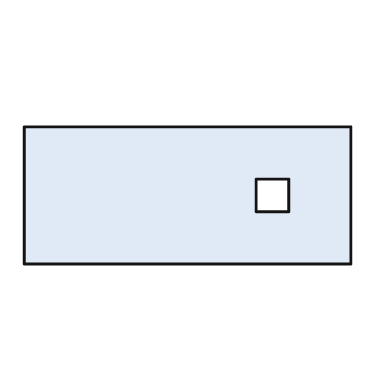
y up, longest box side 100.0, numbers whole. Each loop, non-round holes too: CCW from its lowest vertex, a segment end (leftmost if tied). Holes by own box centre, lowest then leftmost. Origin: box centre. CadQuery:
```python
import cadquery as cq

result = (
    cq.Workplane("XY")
    .moveTo(-50.0, -21.0)
    .lineTo(50.0, -21.0)
    .lineTo(50.0, 21.0)
    .lineTo(-50.0, 21.0)
    .close()
    .moveTo(21.0, -5.0)
    .lineTo(31.0, -5.0)
    .lineTo(31.0, 5.0)
    .lineTo(21.0, 5.0)
    .close()
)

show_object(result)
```